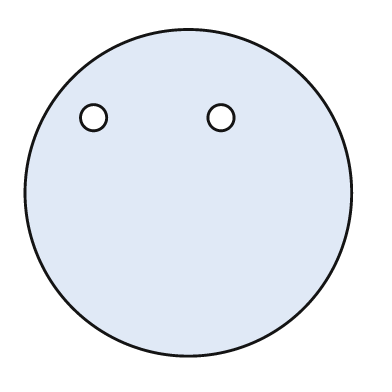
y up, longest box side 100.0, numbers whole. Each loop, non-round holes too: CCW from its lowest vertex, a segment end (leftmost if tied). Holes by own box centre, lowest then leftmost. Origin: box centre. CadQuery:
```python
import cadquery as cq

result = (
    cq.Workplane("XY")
    .moveTo(0.0, 0.0)
    .circle(50.0)
    .moveTo(-29.0, 23.0)
    .circle(4.0)
    .moveTo(10.0, 23.0)
    .circle(4.0)
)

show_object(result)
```